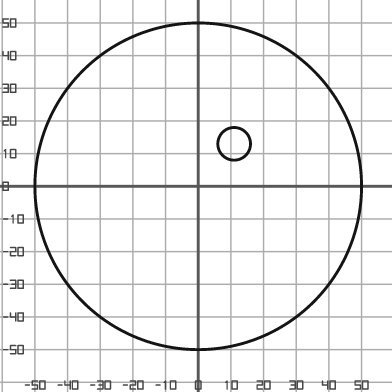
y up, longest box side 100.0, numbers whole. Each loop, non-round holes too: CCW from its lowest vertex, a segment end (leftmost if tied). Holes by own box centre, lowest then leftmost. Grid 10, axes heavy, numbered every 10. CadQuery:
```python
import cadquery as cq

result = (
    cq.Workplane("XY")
    .moveTo(0.0, 0.0)
    .circle(50.0)
    .moveTo(11.0, 13.0)
    .circle(5.0)
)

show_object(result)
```